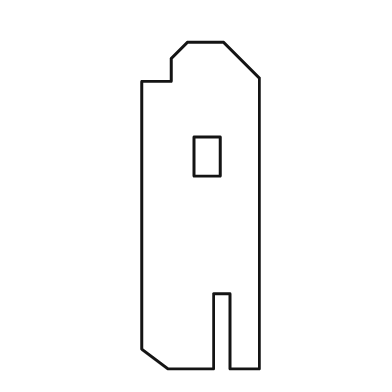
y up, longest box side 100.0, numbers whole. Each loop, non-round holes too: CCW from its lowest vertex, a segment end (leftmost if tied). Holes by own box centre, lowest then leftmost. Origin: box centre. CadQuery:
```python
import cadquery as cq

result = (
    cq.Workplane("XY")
    .moveTo(-10.0, -50.0)
    .lineTo(4.0, -50.0)
    .lineTo(4.0, -27.0)
    .lineTo(9.0, -27.0)
    .lineTo(9.0, -50.0)
    .lineTo(18.0, -50.0)
    .lineTo(18.0, 39.0)
    .lineTo(7.0, 50.0)
    .lineTo(-4.0, 50.0)
    .lineTo(-9.0, 45.0)
    .lineTo(-9.0, 38.0)
    .lineTo(-18.0, 38.0)
    .lineTo(-18.0, -44.0)
    .close()
    .moveTo(-2.0, 9.0)
    .lineTo(6.0, 9.0)
    .lineTo(6.0, 21.0)
    .lineTo(-2.0, 21.0)
    .close()
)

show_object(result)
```